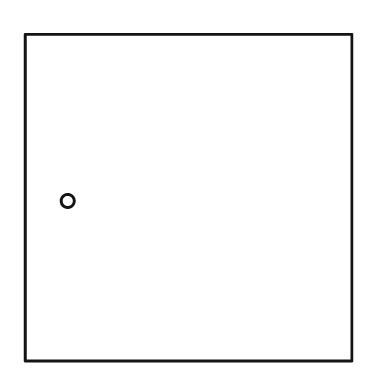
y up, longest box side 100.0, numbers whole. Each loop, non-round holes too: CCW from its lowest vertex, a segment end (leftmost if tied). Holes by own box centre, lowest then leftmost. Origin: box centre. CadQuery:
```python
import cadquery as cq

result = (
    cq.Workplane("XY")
    .moveTo(-50.0, -50.0)
    .lineTo(50.0, -50.0)
    .lineTo(50.0, 50.0)
    .lineTo(-50.0, 50.0)
    .close()
    .moveTo(-37.0, -1.0)
    .circle(2.0)
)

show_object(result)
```